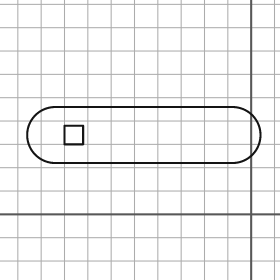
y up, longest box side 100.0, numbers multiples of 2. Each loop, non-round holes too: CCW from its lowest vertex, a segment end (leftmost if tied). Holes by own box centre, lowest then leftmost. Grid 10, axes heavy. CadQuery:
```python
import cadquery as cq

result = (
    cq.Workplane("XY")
    .moveTo(-84.0, 22.0)
    .lineTo(-8.0, 22.0)
    .threePointArc((4.0, 34.0), (-8.0, 46.0))
    .lineTo(-84.0, 46.0)
    .threePointArc((-96.0, 34.0), (-84.0, 22.0))
    .close()
    .moveTo(-80.0, 30.0)
    .lineTo(-72.0, 30.0)
    .lineTo(-72.0, 38.0)
    .lineTo(-80.0, 38.0)
    .close()
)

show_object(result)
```